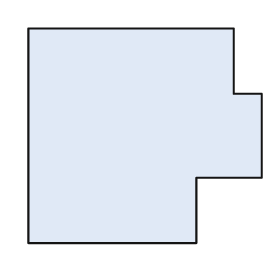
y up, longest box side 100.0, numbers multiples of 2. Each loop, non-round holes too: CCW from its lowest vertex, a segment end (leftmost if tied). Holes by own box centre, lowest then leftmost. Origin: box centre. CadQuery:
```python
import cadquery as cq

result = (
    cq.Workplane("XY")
    .moveTo(-50.0, -46.0)
    .lineTo(22.0, -46.0)
    .lineTo(22.0, -18.0)
    .lineTo(50.0, -18.0)
    .lineTo(50.0, 18.0)
    .lineTo(38.0, 18.0)
    .lineTo(38.0, 46.0)
    .lineTo(-50.0, 46.0)
    .close()
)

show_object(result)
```